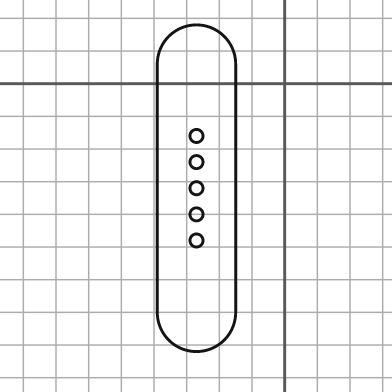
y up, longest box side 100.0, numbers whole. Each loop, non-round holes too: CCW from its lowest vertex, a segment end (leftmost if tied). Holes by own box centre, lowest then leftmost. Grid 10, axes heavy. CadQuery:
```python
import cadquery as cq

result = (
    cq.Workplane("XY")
    .moveTo(-39.0, -70.0)
    .threePointArc((-27.0, -82.0), (-15.0, -70.0))
    .lineTo(-15.0, 6.0)
    .threePointArc((-27.0, 18.0), (-39.0, 6.0))
    .close()
    .moveTo(-27.0, -48.0)
    .circle(2.0)
    .moveTo(-27.0, -40.0)
    .circle(2.0)
    .moveTo(-27.0, -32.0)
    .circle(2.0)
    .moveTo(-27.0, -24.0)
    .circle(2.0)
    .moveTo(-27.0, -16.0)
    .circle(2.0)
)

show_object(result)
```